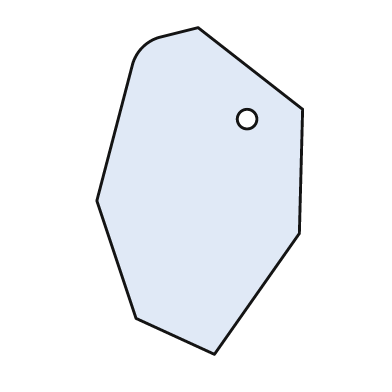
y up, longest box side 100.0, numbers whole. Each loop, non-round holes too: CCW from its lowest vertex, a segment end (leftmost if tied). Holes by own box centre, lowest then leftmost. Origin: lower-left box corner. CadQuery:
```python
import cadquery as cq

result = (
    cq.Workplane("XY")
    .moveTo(36.0, 0.0)
    .lineTo(62.0, 37.0)
    .lineTo(63.0, 75.0)
    .lineTo(31.0, 100.0)
    .lineTo(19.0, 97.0)
    .threePointArc((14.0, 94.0), (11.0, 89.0))
    .lineTo(0.0, 47.0)
    .lineTo(12.0, 11.0)
    .close()
    .moveTo(46.0, 72.0)
    .circle(3.0)
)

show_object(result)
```